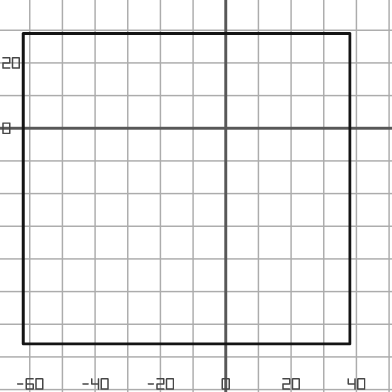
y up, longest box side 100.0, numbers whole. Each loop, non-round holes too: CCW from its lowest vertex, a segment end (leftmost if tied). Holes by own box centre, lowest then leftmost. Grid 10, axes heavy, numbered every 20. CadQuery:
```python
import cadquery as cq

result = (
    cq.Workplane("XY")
    .moveTo(-62.0, -66.0)
    .lineTo(38.0, -66.0)
    .lineTo(38.0, 29.0)
    .lineTo(-62.0, 29.0)
    .close()
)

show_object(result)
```